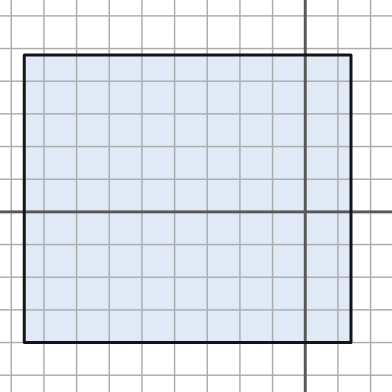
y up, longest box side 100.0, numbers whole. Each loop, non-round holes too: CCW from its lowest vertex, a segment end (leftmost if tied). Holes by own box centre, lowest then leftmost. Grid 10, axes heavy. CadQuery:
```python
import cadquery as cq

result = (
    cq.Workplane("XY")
    .moveTo(-86.0, -40.0)
    .lineTo(14.0, -40.0)
    .lineTo(14.0, 48.0)
    .lineTo(-86.0, 48.0)
    .close()
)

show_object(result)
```